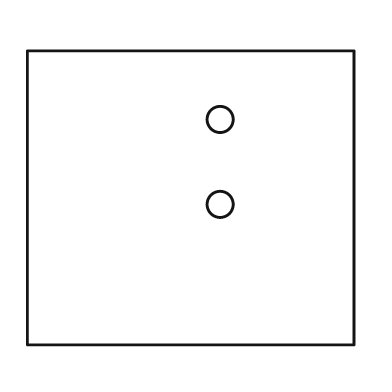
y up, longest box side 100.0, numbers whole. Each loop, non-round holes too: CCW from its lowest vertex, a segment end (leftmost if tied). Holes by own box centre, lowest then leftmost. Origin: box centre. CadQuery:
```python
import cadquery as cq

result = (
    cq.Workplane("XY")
    .moveTo(-50.0, -45.0)
    .lineTo(50.0, -45.0)
    .lineTo(50.0, 45.0)
    .lineTo(-50.0, 45.0)
    .close()
    .moveTo(9.0, -2.0)
    .circle(4.0)
    .moveTo(9.0, 24.0)
    .circle(4.0)
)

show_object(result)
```